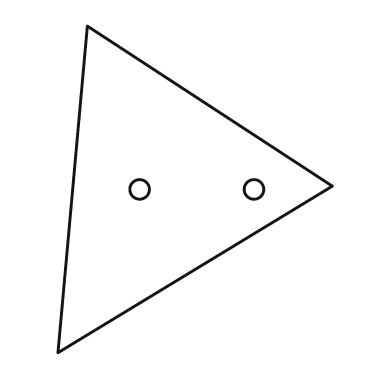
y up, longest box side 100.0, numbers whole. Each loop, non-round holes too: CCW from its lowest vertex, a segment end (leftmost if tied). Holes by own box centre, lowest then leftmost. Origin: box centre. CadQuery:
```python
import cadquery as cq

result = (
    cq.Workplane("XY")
    .moveTo(-42.0, -50.0)
    .lineTo(42.0, 1.0)
    .lineTo(-33.0, 50.0)
    .close()
    .moveTo(-17.0, 0.0)
    .circle(3.0)
    .moveTo(18.0, 0.0)
    .circle(3.0)
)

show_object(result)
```